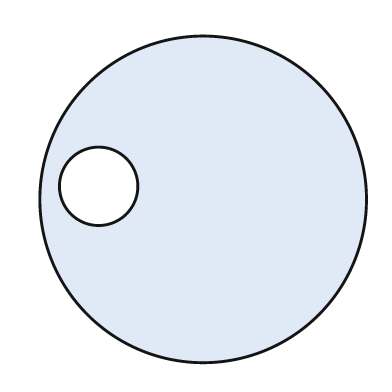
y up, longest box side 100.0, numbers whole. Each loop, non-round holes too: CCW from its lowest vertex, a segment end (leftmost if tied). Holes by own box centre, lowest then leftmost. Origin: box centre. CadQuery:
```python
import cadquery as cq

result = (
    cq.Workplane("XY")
    .moveTo(0.0, 0.0)
    .circle(50.0)
    .moveTo(-32.0, 4.0)
    .circle(12.0)
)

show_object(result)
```